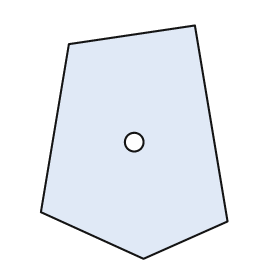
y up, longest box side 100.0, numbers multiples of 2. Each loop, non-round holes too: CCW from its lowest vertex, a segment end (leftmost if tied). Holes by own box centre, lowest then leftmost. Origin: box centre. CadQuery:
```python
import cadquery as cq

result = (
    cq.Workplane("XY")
    .moveTo(4.0, -50.0)
    .lineTo(40.0, -34.0)
    .lineTo(26.0, 50.0)
    .lineTo(-28.0, 42.0)
    .lineTo(-40.0, -30.0)
    .close()
    .moveTo(0.0, 0.0)
    .circle(4.0)
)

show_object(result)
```